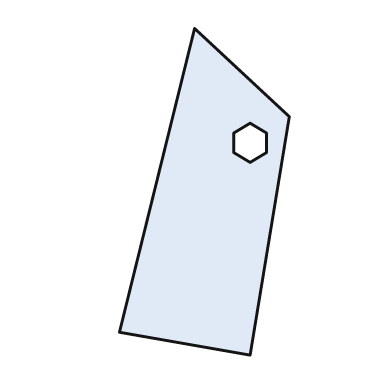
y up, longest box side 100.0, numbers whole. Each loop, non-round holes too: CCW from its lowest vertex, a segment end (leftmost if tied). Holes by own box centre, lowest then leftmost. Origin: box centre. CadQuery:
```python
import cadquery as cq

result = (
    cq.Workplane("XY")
    .moveTo(14.0, -50.0)
    .lineTo(26.0, 23.0)
    .lineTo(-3.0, 50.0)
    .lineTo(-26.0, -43.0)
    .close()
    .moveTo(14.0, 9.0)
    .lineTo(19.0, 12.0)
    .lineTo(19.0, 18.0)
    .lineTo(14.0, 21.0)
    .lineTo(9.0, 18.0)
    .lineTo(9.0, 12.0)
    .close()
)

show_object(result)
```